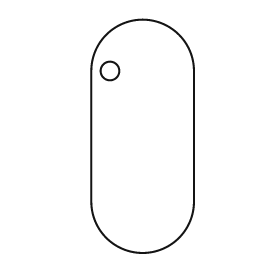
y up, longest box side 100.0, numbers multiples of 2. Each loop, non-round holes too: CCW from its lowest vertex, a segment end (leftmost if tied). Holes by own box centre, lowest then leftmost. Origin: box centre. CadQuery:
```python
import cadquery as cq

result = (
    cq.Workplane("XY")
    .moveTo(-22.0, -28.0)
    .threePointArc((0.0, -50.0), (22.0, -28.0))
    .lineTo(22.0, 28.0)
    .threePointArc((0.0, 50.0), (-22.0, 28.0))
    .close()
    .moveTo(-14.0, 28.0)
    .circle(4.0)
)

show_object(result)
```